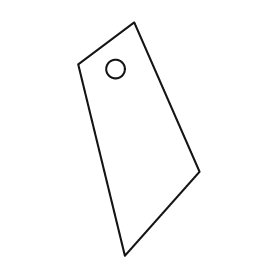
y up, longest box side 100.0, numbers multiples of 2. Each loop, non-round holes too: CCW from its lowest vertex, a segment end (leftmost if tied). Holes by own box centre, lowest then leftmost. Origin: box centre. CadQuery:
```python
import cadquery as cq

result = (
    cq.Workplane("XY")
    .moveTo(-6.0, -50.0)
    .lineTo(26.0, -14.0)
    .lineTo(-2.0, 50.0)
    .lineTo(-26.0, 32.0)
    .close()
    .moveTo(-10.0, 30.0)
    .circle(4.0)
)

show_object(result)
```